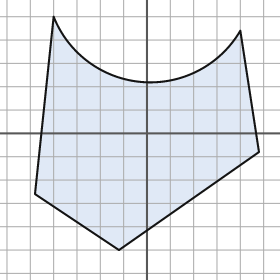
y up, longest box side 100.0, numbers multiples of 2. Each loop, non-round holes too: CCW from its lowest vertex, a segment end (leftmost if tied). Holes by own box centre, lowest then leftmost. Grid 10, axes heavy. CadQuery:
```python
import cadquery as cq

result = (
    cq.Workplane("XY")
    .moveTo(-12.0, -50.0)
    .lineTo(48.0, -8.0)
    .lineTo(40.0, 44.0)
    .threePointArc((-2.0, 22.0), (-40.0, 50.0))
    .lineTo(-48.0, -26.0)
    .close()
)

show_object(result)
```